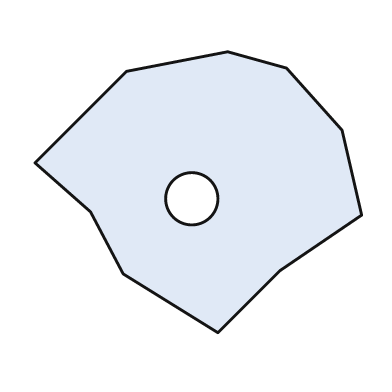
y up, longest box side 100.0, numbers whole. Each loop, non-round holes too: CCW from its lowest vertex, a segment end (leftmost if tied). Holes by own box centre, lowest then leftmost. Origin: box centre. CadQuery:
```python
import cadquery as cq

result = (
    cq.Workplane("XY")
    .moveTo(6.0, -43.0)
    .lineTo(25.0, -24.0)
    .lineTo(50.0, -7.0)
    .lineTo(44.0, 19.0)
    .lineTo(27.0, 38.0)
    .lineTo(9.0, 43.0)
    .lineTo(-22.0, 37.0)
    .lineTo(-50.0, 9.0)
    .lineTo(-33.0, -6.0)
    .lineTo(-23.0, -25.0)
    .close()
    .moveTo(-2.0, -2.0)
    .circle(8.0)
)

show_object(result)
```